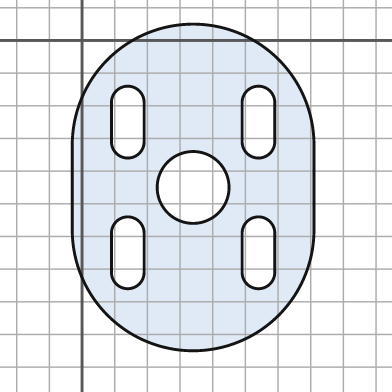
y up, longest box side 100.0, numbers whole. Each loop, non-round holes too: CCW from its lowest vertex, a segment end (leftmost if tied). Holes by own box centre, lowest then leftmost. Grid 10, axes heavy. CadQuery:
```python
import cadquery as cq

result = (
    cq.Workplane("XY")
    .moveTo(-3.0, -58.0)
    .threePointArc((34.0, -95.0), (71.0, -58.0))
    .lineTo(71.0, -32.0)
    .threePointArc((34.0, 5.0), (-3.0, -32.0))
    .close()
    .moveTo(9.0, -71.0)
    .threePointArc((14.0, -76.0), (19.0, -71.0))
    .lineTo(19.0, -59.0)
    .threePointArc((14.0, -54.0), (9.0, -59.0))
    .close()
    .moveTo(49.0, -71.0)
    .threePointArc((54.0, -76.0), (59.0, -71.0))
    .lineTo(59.0, -59.0)
    .threePointArc((54.0, -54.0), (49.0, -59.0))
    .close()
    .moveTo(34.0, -45.0)
    .circle(11.0)
    .moveTo(9.0, -31.0)
    .threePointArc((14.0, -36.0), (19.0, -31.0))
    .lineTo(19.0, -19.0)
    .threePointArc((14.0, -14.0), (9.0, -19.0))
    .close()
    .moveTo(49.0, -31.0)
    .threePointArc((54.0, -36.0), (59.0, -31.0))
    .lineTo(59.0, -19.0)
    .threePointArc((54.0, -14.0), (49.0, -19.0))
    .close()
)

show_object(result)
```